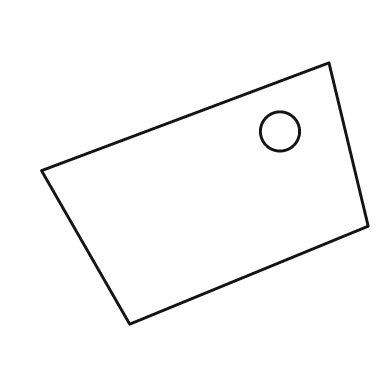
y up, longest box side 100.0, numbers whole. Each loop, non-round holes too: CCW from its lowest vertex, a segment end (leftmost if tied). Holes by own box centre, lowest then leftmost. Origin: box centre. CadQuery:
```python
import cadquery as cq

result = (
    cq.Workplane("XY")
    .moveTo(-23.0, -40.0)
    .lineTo(50.0, -10.0)
    .lineTo(38.0, 40.0)
    .lineTo(-50.0, 7.0)
    .close()
    .moveTo(23.0, 19.0)
    .circle(6.0)
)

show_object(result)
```